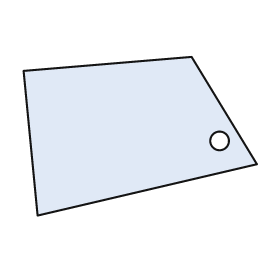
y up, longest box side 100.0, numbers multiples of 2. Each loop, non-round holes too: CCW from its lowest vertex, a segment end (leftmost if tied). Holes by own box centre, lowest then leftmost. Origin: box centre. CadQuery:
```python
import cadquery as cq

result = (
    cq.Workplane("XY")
    .moveTo(-44.0, -34.0)
    .lineTo(50.0, -12.0)
    .lineTo(22.0, 34.0)
    .lineTo(-50.0, 28.0)
    .close()
    .moveTo(34.0, -2.0)
    .circle(4.0)
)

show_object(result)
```